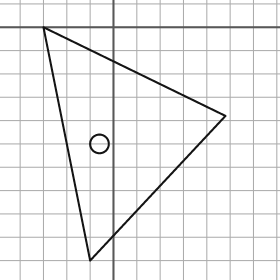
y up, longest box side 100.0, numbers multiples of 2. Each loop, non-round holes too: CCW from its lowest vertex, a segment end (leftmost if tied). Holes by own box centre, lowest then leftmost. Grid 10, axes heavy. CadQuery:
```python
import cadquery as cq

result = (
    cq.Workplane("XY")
    .moveTo(-10.0, -100.0)
    .lineTo(48.0, -38.0)
    .lineTo(-30.0, 0.0)
    .close()
    .moveTo(-6.0, -50.0)
    .circle(4.0)
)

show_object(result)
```